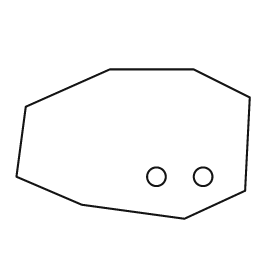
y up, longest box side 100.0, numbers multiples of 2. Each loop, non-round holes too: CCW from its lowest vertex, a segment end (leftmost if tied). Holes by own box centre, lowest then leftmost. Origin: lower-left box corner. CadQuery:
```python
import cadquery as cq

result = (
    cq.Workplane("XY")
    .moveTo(72.0, 0.0)
    .lineTo(98.0, 12.0)
    .lineTo(100.0, 52.0)
    .lineTo(76.0, 64.0)
    .lineTo(40.0, 64.0)
    .lineTo(4.0, 48.0)
    .lineTo(0.0, 18.0)
    .lineTo(28.0, 6.0)
    .close()
    .moveTo(60.0, 18.0)
    .circle(4.0)
    .moveTo(80.0, 18.0)
    .circle(4.0)
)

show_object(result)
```